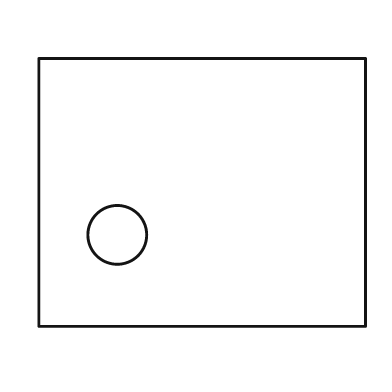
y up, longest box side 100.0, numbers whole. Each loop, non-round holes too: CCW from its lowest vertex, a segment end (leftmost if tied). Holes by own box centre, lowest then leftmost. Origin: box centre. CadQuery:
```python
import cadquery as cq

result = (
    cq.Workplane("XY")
    .moveTo(-50.0, -41.0)
    .lineTo(50.0, -41.0)
    .lineTo(50.0, 41.0)
    .lineTo(-50.0, 41.0)
    .close()
    .moveTo(-26.0, -13.0)
    .circle(9.0)
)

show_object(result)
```